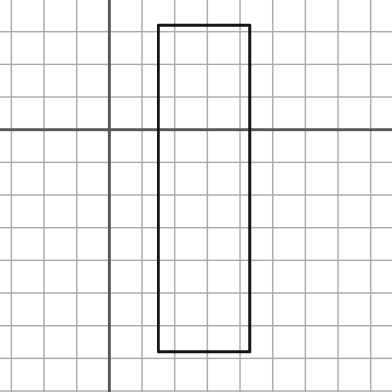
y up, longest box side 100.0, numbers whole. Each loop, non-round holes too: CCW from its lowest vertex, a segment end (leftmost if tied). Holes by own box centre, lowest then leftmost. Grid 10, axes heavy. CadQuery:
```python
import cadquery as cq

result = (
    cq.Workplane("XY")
    .moveTo(15.0, -68.0)
    .lineTo(43.0, -68.0)
    .lineTo(43.0, 32.0)
    .lineTo(15.0, 32.0)
    .close()
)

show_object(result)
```